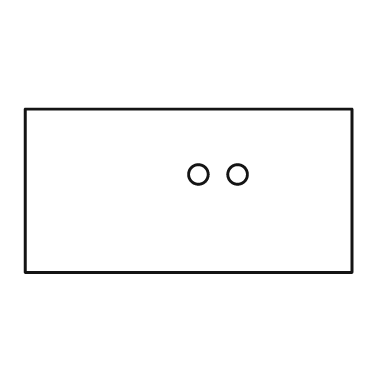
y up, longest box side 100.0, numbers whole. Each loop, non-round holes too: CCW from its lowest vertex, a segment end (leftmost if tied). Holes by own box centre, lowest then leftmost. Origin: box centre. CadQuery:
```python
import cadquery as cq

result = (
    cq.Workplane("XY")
    .moveTo(-50.0, -25.0)
    .lineTo(50.0, -25.0)
    .lineTo(50.0, 25.0)
    .lineTo(-50.0, 25.0)
    .close()
    .moveTo(3.0, 5.0)
    .circle(3.0)
    .moveTo(15.0, 5.0)
    .circle(3.0)
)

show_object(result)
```